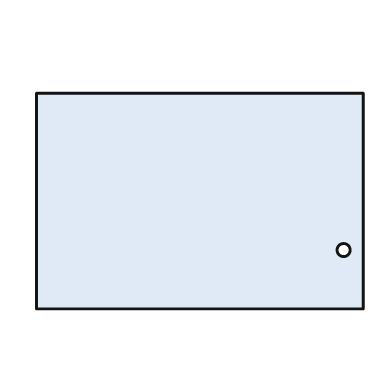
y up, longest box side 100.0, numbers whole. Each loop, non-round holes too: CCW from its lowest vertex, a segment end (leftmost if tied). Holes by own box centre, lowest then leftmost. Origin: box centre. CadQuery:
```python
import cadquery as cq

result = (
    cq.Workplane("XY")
    .moveTo(-50.0, -33.0)
    .lineTo(50.0, -33.0)
    .lineTo(50.0, 33.0)
    .lineTo(-50.0, 33.0)
    .close()
    .moveTo(44.0, -15.0)
    .circle(2.0)
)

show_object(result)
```